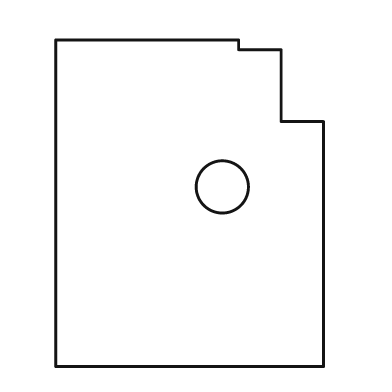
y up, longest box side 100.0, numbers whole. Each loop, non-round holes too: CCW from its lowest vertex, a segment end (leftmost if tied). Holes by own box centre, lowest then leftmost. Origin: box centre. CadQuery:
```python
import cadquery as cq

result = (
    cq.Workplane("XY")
    .moveTo(-41.0, -50.0)
    .lineTo(41.0, -50.0)
    .lineTo(41.0, 25.0)
    .lineTo(28.0, 25.0)
    .lineTo(28.0, 47.0)
    .lineTo(15.0, 47.0)
    .lineTo(15.0, 50.0)
    .lineTo(-41.0, 50.0)
    .close()
    .moveTo(10.0, 5.0)
    .circle(8.0)
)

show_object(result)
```